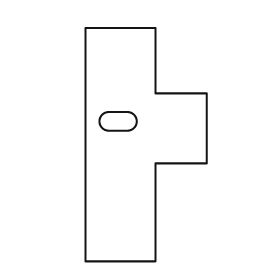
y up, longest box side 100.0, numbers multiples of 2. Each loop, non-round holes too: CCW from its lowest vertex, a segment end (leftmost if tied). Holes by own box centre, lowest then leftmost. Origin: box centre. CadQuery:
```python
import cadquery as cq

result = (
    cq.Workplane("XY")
    .moveTo(-26.0, -50.0)
    .lineTo(4.0, -50.0)
    .lineTo(4.0, -8.0)
    .lineTo(26.0, -8.0)
    .lineTo(26.0, 22.0)
    .lineTo(4.0, 22.0)
    .lineTo(4.0, 50.0)
    .lineTo(-26.0, 50.0)
    .close()
    .moveTo(-16.0, 6.0)
    .lineTo(-8.0, 6.0)
    .threePointArc((-4.0, 10.0), (-8.0, 14.0))
    .lineTo(-16.0, 14.0)
    .threePointArc((-20.0, 10.0), (-16.0, 6.0))
    .close()
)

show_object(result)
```